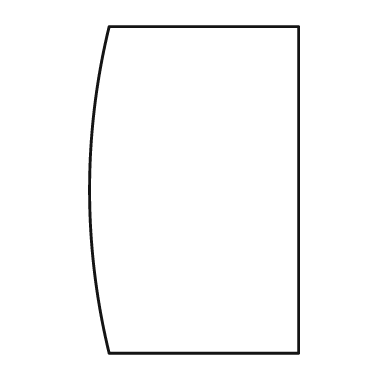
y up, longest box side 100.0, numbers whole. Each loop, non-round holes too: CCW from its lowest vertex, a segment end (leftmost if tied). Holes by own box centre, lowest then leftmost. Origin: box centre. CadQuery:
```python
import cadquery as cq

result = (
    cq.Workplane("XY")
    .moveTo(-26.0, -50.0)
    .lineTo(32.0, -50.0)
    .lineTo(32.0, 50.0)
    .lineTo(-26.0, 50.0)
    .threePointArc((-32.0, 0.0), (-26.0, -50.0))
    .close()
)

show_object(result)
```